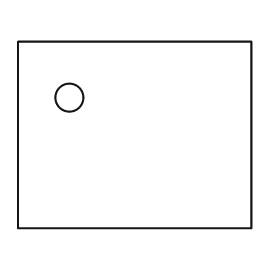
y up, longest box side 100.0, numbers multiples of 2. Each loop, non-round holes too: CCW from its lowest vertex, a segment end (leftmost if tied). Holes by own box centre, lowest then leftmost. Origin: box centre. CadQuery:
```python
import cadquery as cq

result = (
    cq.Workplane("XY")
    .moveTo(-50.0, -40.0)
    .lineTo(50.0, -40.0)
    .lineTo(50.0, 40.0)
    .lineTo(-50.0, 40.0)
    .close()
    .moveTo(-28.0, 16.0)
    .circle(6.0)
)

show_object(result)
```